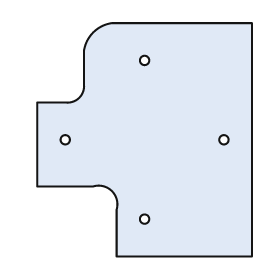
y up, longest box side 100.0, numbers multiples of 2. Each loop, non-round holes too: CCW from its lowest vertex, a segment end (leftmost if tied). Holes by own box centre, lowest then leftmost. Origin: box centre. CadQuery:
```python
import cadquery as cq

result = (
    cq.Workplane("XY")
    .moveTo(-12.0, -50.0)
    .lineTo(46.0, -50.0)
    .lineTo(46.0, 50.0)
    .lineTo(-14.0, 50.0)
    .threePointArc((-22.0, 46.0), (-26.0, 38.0))
    .lineTo(-26.0, 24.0)
    .threePointArc((-28.0, 18.0), (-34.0, 16.0))
    .lineTo(-46.0, 16.0)
    .lineTo(-46.0, -20.0)
    .lineTo(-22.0, -20.0)
    .threePointArc((-14.0, -22.0), (-12.0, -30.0))
    .close()
    .moveTo(0.0, -34.0)
    .circle(2.0)
    .moveTo(-34.0, 0.0)
    .circle(2.0)
    .moveTo(34.0, 0.0)
    .circle(2.0)
    .moveTo(0.0, 34.0)
    .circle(2.0)
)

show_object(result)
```